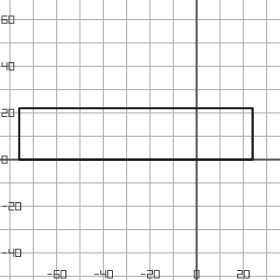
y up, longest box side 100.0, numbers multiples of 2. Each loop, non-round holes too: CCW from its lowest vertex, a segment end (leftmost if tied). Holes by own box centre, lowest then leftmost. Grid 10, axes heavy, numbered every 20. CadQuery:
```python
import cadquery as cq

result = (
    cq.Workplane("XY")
    .moveTo(-76.0, 0.0)
    .lineTo(24.0, 0.0)
    .lineTo(24.0, 22.0)
    .lineTo(-76.0, 22.0)
    .close()
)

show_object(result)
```